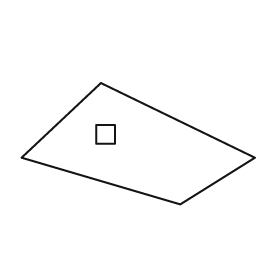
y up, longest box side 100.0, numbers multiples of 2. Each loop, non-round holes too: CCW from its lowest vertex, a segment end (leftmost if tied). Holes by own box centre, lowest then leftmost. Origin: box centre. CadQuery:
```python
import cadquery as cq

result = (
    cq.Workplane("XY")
    .moveTo(18.0, -26.0)
    .lineTo(50.0, -6.0)
    .lineTo(-16.0, 26.0)
    .lineTo(-50.0, -6.0)
    .close()
    .moveTo(-18.0, 0.0)
    .lineTo(-10.0, 0.0)
    .lineTo(-10.0, 8.0)
    .lineTo(-18.0, 8.0)
    .close()
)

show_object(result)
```